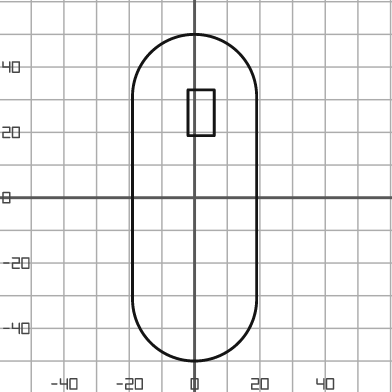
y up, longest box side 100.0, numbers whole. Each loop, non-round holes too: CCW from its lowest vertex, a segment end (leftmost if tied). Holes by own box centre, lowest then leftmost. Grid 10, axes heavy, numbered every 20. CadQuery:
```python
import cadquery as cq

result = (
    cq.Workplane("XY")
    .moveTo(-19.0, -31.0)
    .threePointArc((0.0, -50.0), (19.0, -31.0))
    .lineTo(19.0, 31.0)
    .threePointArc((0.0, 50.0), (-19.0, 31.0))
    .close()
    .moveTo(-2.0, 19.0)
    .lineTo(6.0, 19.0)
    .lineTo(6.0, 33.0)
    .lineTo(-2.0, 33.0)
    .close()
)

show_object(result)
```